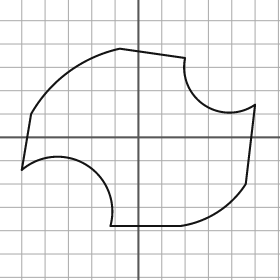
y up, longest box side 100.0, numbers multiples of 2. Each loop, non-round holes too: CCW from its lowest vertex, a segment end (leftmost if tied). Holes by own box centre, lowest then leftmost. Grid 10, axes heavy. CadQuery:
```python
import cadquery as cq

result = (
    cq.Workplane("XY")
    .moveTo(-12.0, -38.0)
    .lineTo(18.0, -38.0)
    .threePointArc((34.0, -32.0), (46.0, -20.0))
    .lineTo(50.0, 14.0)
    .threePointArc((28.0, 14.0), (20.0, 34.0))
    .lineTo(-8.0, 38.0)
    .threePointArc((-30.0, 28.0), (-46.0, 10.0))
    .lineTo(-50.0, -14.0)
    .threePointArc((-22.0, -12.0), (-12.0, -38.0))
    .close()
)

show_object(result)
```